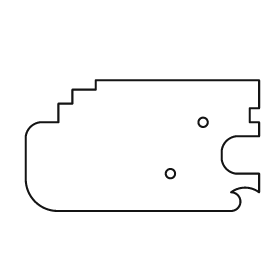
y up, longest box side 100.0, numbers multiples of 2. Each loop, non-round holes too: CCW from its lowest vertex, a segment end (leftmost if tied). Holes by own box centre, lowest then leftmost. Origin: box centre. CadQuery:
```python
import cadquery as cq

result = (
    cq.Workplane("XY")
    .moveTo(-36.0, -28.0)
    .lineTo(38.0, -28.0)
    .threePointArc((42.0, -24.0), (38.0, -20.0))
    .threePointArc((44.0, -18.0), (50.0, -20.0))
    .lineTo(50.0, -12.0)
    .lineTo(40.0, -12.0)
    .threePointArc((36.0, -10.0), (34.0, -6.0))
    .lineTo(34.0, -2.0)
    .threePointArc((36.0, 2.0), (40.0, 4.0))
    .lineTo(50.0, 4.0)
    .lineTo(50.0, 10.0)
    .lineTo(46.0, 10.0)
    .lineTo(46.0, 16.0)
    .lineTo(50.0, 16.0)
    .lineTo(50.0, 28.0)
    .lineTo(-20.0, 28.0)
    .lineTo(-20.0, 24.0)
    .lineTo(-30.0, 24.0)
    .lineTo(-30.0, 18.0)
    .lineTo(-36.0, 18.0)
    .lineTo(-36.0, 10.0)
    .lineTo(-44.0, 10.0)
    .threePointArc((-48.0, 8.0), (-50.0, 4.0))
    .lineTo(-50.0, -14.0)
    .threePointArc((-46.0, -24.0), (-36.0, -28.0))
    .close()
    .moveTo(12.0, -12.0)
    .circle(2.0)
    .moveTo(26.0, 10.0)
    .circle(2.0)
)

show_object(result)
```